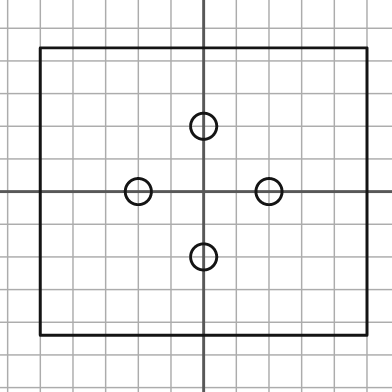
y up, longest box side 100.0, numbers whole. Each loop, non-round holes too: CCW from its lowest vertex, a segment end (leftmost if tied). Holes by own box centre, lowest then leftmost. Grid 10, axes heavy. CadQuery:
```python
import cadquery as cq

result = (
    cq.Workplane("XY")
    .moveTo(-50.0, -44.0)
    .lineTo(50.0, -44.0)
    .lineTo(50.0, 44.0)
    .lineTo(-50.0, 44.0)
    .close()
    .moveTo(0.0, -20.0)
    .circle(4.0)
    .moveTo(-20.0, 0.0)
    .circle(4.0)
    .moveTo(20.0, 0.0)
    .circle(4.0)
    .moveTo(0.0, 20.0)
    .circle(4.0)
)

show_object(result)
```